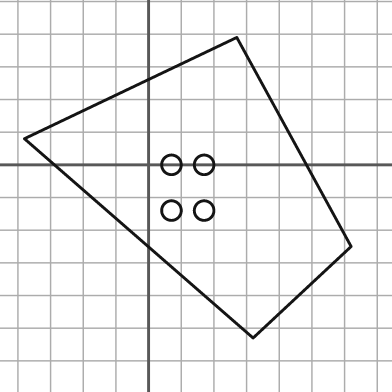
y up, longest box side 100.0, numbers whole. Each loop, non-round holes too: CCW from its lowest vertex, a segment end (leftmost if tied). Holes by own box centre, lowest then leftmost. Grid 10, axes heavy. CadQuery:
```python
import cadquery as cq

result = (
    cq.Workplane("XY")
    .moveTo(32.0, -53.0)
    .lineTo(62.0, -25.0)
    .lineTo(27.0, 39.0)
    .lineTo(-38.0, 8.0)
    .close()
    .moveTo(7.0, -14.0)
    .circle(3.0)
    .moveTo(17.0, -14.0)
    .circle(3.0)
    .moveTo(7.0, 0.0)
    .circle(3.0)
    .moveTo(17.0, 0.0)
    .circle(3.0)
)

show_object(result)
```